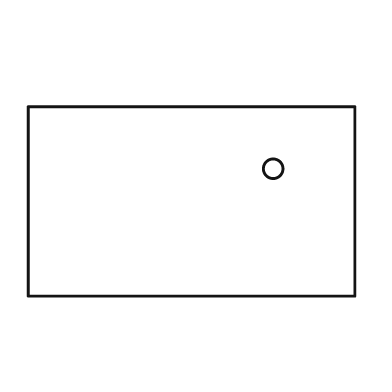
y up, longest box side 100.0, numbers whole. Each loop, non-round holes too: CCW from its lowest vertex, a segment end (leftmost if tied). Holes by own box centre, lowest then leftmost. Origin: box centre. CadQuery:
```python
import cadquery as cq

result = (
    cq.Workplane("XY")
    .moveTo(-50.0, -29.0)
    .lineTo(50.0, -29.0)
    .lineTo(50.0, 29.0)
    .lineTo(-50.0, 29.0)
    .close()
    .moveTo(25.0, 10.0)
    .circle(3.0)
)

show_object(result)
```